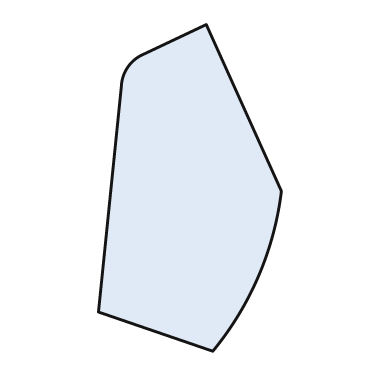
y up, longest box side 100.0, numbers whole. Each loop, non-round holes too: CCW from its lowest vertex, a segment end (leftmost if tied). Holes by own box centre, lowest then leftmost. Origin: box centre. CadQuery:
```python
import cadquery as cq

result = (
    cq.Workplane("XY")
    .moveTo(7.0, -50.0)
    .threePointArc((21.0, -27.0), (28.0, -1.0))
    .lineTo(5.0, 50.0)
    .lineTo(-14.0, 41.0)
    .threePointArc((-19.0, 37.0), (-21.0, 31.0))
    .lineTo(-28.0, -38.0)
    .close()
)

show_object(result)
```